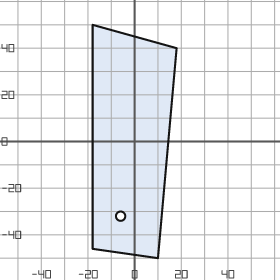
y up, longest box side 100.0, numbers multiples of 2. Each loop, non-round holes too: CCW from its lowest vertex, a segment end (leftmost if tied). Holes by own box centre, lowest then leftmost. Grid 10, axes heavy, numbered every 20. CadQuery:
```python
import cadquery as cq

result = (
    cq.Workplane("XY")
    .moveTo(10.0, -50.0)
    .lineTo(18.0, 40.0)
    .lineTo(-18.0, 50.0)
    .lineTo(-18.0, -46.0)
    .close()
    .moveTo(-6.0, -32.0)
    .circle(2.0)
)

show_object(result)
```